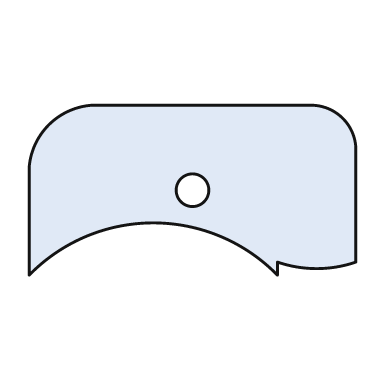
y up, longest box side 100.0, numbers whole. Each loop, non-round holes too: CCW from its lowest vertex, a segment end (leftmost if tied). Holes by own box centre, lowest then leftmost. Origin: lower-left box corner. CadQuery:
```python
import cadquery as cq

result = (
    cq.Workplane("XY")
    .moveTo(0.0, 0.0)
    .threePointArc((38.0, 16.0), (76.0, 0.0))
    .lineTo(76.0, 4.0)
    .threePointArc((88.0, 2.0), (100.0, 4.0))
    .lineTo(100.0, 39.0)
    .threePointArc((96.0, 48.0), (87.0, 52.0))
    .lineTo(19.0, 52.0)
    .threePointArc((6.0, 46.0), (0.0, 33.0))
    .close()
    .moveTo(50.0, 26.0)
    .circle(5.0)
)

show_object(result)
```